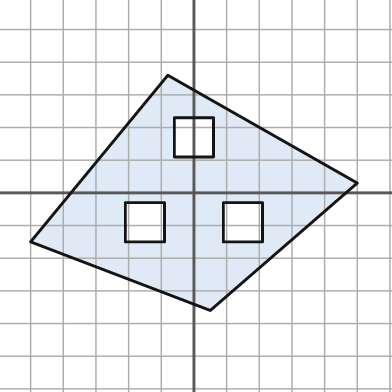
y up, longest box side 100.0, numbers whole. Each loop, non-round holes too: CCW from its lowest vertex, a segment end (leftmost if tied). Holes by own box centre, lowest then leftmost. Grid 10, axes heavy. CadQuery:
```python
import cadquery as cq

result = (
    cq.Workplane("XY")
    .moveTo(5.0, -36.0)
    .lineTo(50.0, 3.0)
    .lineTo(-8.0, 36.0)
    .lineTo(-50.0, -15.0)
    .close()
    .moveTo(-21.0, -15.0)
    .lineTo(-9.0, -15.0)
    .lineTo(-9.0, -3.0)
    .lineTo(-21.0, -3.0)
    .close()
    .moveTo(9.0, -15.0)
    .lineTo(21.0, -15.0)
    .lineTo(21.0, -3.0)
    .lineTo(9.0, -3.0)
    .close()
    .moveTo(-6.0, 11.0)
    .lineTo(6.0, 11.0)
    .lineTo(6.0, 23.0)
    .lineTo(-6.0, 23.0)
    .close()
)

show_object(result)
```